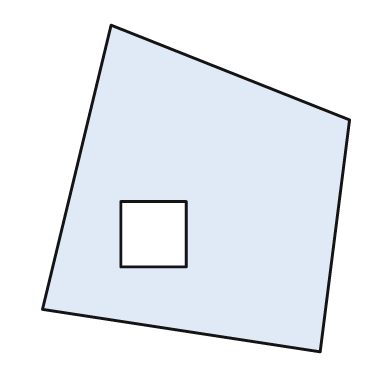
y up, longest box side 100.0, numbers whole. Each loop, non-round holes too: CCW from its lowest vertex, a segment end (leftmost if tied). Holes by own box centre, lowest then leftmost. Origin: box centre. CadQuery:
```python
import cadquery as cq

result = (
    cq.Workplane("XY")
    .moveTo(38.0, -50.0)
    .lineTo(47.0, 21.0)
    .lineTo(-26.0, 50.0)
    .lineTo(-47.0, -37.0)
    .close()
    .moveTo(-23.0, -24.0)
    .lineTo(-3.0, -24.0)
    .lineTo(-3.0, -4.0)
    .lineTo(-23.0, -4.0)
    .close()
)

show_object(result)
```